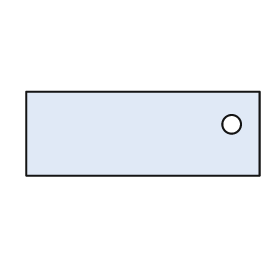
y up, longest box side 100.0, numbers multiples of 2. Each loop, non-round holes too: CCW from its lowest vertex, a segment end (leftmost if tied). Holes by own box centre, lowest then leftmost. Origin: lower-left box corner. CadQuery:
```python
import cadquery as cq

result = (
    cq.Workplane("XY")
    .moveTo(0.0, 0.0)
    .lineTo(100.0, 0.0)
    .lineTo(100.0, 36.0)
    .lineTo(0.0, 36.0)
    .close()
    .moveTo(88.0, 22.0)
    .circle(4.0)
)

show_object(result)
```